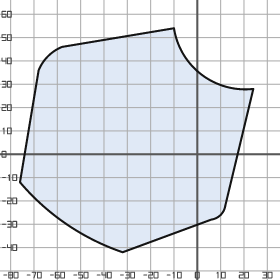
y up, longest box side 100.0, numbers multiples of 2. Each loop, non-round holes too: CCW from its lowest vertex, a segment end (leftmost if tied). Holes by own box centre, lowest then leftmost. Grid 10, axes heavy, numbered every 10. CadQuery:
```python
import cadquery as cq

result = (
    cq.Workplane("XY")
    .moveTo(-32.0, -42.0)
    .lineTo(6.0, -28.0)
    .threePointArc((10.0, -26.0), (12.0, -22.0))
    .lineTo(24.0, 28.0)
    .threePointArc((2.0, 34.0), (-10.0, 54.0))
    .lineTo(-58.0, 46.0)
    .threePointArc((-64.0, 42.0), (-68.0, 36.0))
    .lineTo(-76.0, -12.0)
    .threePointArc((-56.0, -30.0), (-32.0, -42.0))
    .close()
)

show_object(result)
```